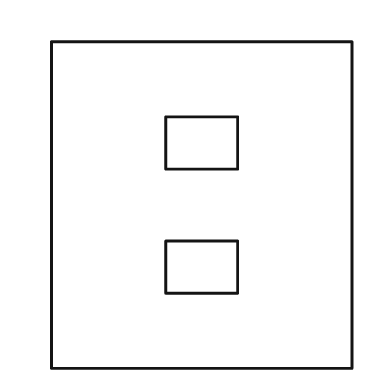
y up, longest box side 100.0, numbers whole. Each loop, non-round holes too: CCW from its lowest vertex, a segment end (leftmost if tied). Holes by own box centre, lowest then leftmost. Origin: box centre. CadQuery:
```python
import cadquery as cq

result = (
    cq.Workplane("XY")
    .moveTo(-46.0, -50.0)
    .lineTo(46.0, -50.0)
    .lineTo(46.0, 50.0)
    .lineTo(-46.0, 50.0)
    .close()
    .moveTo(-11.0, -27.0)
    .lineTo(11.0, -27.0)
    .lineTo(11.0, -11.0)
    .lineTo(-11.0, -11.0)
    .close()
    .moveTo(-11.0, 11.0)
    .lineTo(11.0, 11.0)
    .lineTo(11.0, 27.0)
    .lineTo(-11.0, 27.0)
    .close()
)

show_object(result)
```